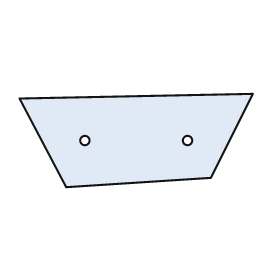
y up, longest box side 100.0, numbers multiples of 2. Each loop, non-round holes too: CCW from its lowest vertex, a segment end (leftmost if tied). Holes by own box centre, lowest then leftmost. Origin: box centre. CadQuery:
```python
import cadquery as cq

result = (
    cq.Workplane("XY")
    .moveTo(-30.0, -20.0)
    .lineTo(32.0, -16.0)
    .lineTo(50.0, 20.0)
    .lineTo(-50.0, 18.0)
    .close()
    .moveTo(-22.0, 0.0)
    .circle(2.0)
    .moveTo(22.0, 0.0)
    .circle(2.0)
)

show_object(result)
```